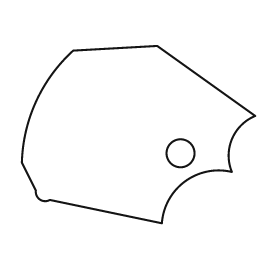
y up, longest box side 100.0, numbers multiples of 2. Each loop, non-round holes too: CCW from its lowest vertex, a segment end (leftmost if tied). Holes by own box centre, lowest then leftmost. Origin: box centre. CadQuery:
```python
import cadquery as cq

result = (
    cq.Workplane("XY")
    .moveTo(10.0, -38.0)
    .threePointArc((20.0, -20.0), (40.0, -16.0))
    .threePointArc((40.0, -2.0), (50.0, 8.0))
    .lineTo(8.0, 38.0)
    .lineTo(-28.0, 36.0)
    .threePointArc((-44.0, 14.0), (-50.0, -12.0))
    .lineTo(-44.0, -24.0)
    .threePointArc((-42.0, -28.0), (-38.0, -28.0))
    .close()
    .moveTo(18.0, -8.0)
    .circle(6.0)
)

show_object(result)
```